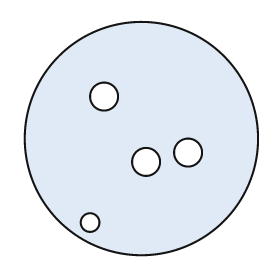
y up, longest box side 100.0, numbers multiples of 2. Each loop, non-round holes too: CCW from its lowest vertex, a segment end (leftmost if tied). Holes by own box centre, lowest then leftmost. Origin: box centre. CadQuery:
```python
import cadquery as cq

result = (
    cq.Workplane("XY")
    .moveTo(0.0, 0.0)
    .circle(50.0)
    .moveTo(-22.0, -36.0)
    .circle(4.0)
    .moveTo(2.0, -10.0)
    .circle(6.0)
    .moveTo(20.0, -6.0)
    .circle(6.0)
    .moveTo(-16.0, 18.0)
    .circle(6.0)
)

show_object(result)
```